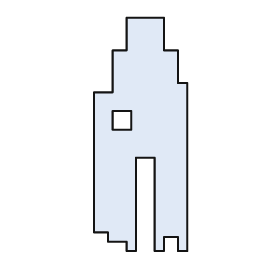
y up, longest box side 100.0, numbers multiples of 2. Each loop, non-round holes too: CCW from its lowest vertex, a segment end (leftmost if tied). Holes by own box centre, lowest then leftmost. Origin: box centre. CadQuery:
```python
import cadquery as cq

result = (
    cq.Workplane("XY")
    .moveTo(-6.0, -50.0)
    .lineTo(-2.0, -50.0)
    .lineTo(-2.0, -10.0)
    .lineTo(6.0, -10.0)
    .lineTo(6.0, -50.0)
    .lineTo(10.0, -50.0)
    .lineTo(10.0, -44.0)
    .lineTo(16.0, -44.0)
    .lineTo(16.0, -50.0)
    .lineTo(20.0, -50.0)
    .lineTo(20.0, 22.0)
    .lineTo(16.0, 22.0)
    .lineTo(16.0, 36.0)
    .lineTo(10.0, 36.0)
    .lineTo(10.0, 50.0)
    .lineTo(-6.0, 50.0)
    .lineTo(-6.0, 36.0)
    .lineTo(-12.0, 36.0)
    .lineTo(-12.0, 18.0)
    .lineTo(-20.0, 18.0)
    .lineTo(-20.0, -42.0)
    .lineTo(-14.0, -42.0)
    .lineTo(-14.0, -46.0)
    .lineTo(-6.0, -46.0)
    .close()
    .moveTo(-12.0, 2.0)
    .lineTo(-4.0, 2.0)
    .lineTo(-4.0, 10.0)
    .lineTo(-12.0, 10.0)
    .close()
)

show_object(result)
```